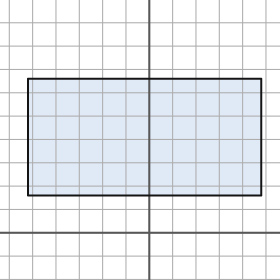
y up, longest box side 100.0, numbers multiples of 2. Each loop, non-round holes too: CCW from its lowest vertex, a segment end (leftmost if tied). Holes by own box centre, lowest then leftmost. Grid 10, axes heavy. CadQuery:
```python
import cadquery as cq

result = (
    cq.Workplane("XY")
    .moveTo(-52.0, 16.0)
    .lineTo(48.0, 16.0)
    .lineTo(48.0, 66.0)
    .lineTo(-52.0, 66.0)
    .close()
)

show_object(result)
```